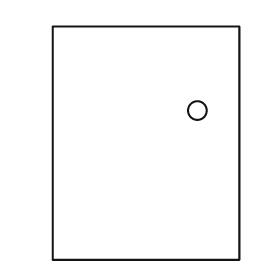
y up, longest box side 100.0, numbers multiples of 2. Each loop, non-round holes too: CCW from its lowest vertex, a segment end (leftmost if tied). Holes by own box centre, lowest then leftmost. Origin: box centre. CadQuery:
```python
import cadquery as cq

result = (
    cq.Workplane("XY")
    .moveTo(-40.0, -50.0)
    .lineTo(40.0, -50.0)
    .lineTo(40.0, 50.0)
    .lineTo(-40.0, 50.0)
    .close()
    .moveTo(22.0, 14.0)
    .circle(4.0)
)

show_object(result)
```